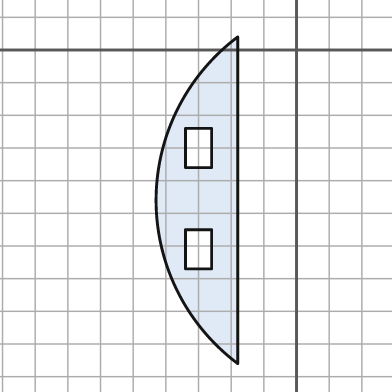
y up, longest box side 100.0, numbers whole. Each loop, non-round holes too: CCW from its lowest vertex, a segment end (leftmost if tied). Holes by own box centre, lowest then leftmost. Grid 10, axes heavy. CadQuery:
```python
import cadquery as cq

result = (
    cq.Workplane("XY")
    .moveTo(-18.0, -96.0)
    .lineTo(-18.0, 4.0)
    .threePointArc((-43.0, -46.0), (-18.0, -96.0))
    .close()
    .moveTo(-34.0, -67.0)
    .lineTo(-26.0, -67.0)
    .lineTo(-26.0, -55.0)
    .lineTo(-34.0, -55.0)
    .close()
    .moveTo(-34.0, -36.0)
    .lineTo(-26.0, -36.0)
    .lineTo(-26.0, -24.0)
    .lineTo(-34.0, -24.0)
    .close()
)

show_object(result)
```